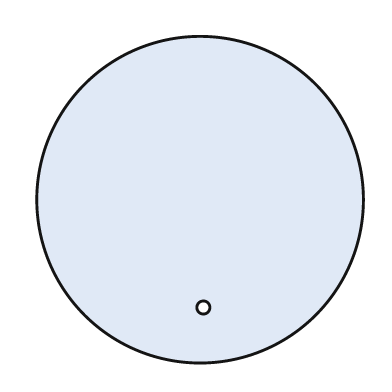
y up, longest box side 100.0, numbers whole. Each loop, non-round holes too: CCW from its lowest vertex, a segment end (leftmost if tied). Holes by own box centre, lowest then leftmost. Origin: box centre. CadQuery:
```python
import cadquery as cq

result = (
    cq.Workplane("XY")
    .moveTo(0.0, 0.0)
    .circle(50.0)
    .moveTo(1.0, -33.0)
    .circle(2.0)
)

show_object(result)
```